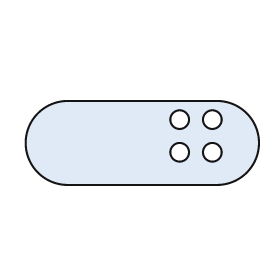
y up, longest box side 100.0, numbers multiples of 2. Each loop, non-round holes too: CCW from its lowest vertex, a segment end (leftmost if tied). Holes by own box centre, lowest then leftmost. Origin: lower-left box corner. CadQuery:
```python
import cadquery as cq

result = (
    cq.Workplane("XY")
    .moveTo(18.0, 0.0)
    .lineTo(82.0, 0.0)
    .threePointArc((100.0, 18.0), (82.0, 36.0))
    .lineTo(18.0, 36.0)
    .threePointArc((0.0, 18.0), (18.0, 0.0))
    .close()
    .moveTo(66.0, 14.0)
    .circle(4.0)
    .moveTo(80.0, 14.0)
    .circle(4.0)
    .moveTo(66.0, 28.0)
    .circle(4.0)
    .moveTo(80.0, 28.0)
    .circle(4.0)
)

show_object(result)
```